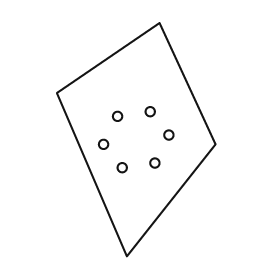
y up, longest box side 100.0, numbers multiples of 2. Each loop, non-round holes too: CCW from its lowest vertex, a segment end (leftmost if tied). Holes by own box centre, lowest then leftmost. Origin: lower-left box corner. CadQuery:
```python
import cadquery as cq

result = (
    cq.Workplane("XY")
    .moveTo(30.0, 0.0)
    .lineTo(68.0, 48.0)
    .lineTo(44.0, 100.0)
    .lineTo(0.0, 70.0)
    .close()
    .moveTo(28.0, 38.0)
    .circle(2.0)
    .moveTo(42.0, 40.0)
    .circle(2.0)
    .moveTo(20.0, 48.0)
    .circle(2.0)
    .moveTo(48.0, 52.0)
    .circle(2.0)
    .moveTo(26.0, 60.0)
    .circle(2.0)
    .moveTo(40.0, 62.0)
    .circle(2.0)
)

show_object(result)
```